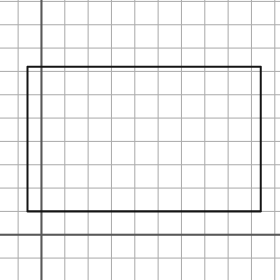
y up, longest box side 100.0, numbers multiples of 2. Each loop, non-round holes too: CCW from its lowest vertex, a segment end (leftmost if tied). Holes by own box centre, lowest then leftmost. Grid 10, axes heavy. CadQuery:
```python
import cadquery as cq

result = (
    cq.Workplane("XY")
    .moveTo(-6.0, 10.0)
    .lineTo(94.0, 10.0)
    .lineTo(94.0, 72.0)
    .lineTo(-6.0, 72.0)
    .close()
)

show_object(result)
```